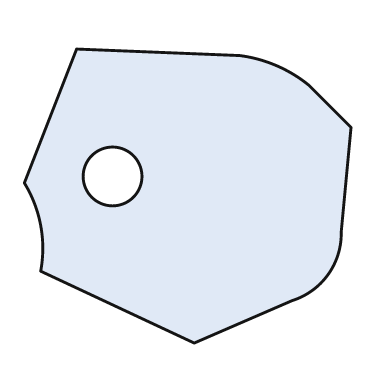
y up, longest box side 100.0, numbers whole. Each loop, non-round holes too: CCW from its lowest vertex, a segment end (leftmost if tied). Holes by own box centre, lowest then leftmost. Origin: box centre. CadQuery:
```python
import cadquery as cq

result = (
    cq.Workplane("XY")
    .moveTo(2.0, -45.0)
    .lineTo(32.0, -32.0)
    .threePointArc((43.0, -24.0), (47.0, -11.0))
    .lineTo(50.0, 21.0)
    .lineTo(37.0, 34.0)
    .threePointArc((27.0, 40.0), (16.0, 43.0))
    .lineTo(-34.0, 45.0)
    .lineTo(-50.0, 4.0)
    .threePointArc((-45.0, -9.0), (-45.0, -23.0))
    .close()
    .moveTo(-23.0, 6.0)
    .circle(9.0)
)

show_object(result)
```